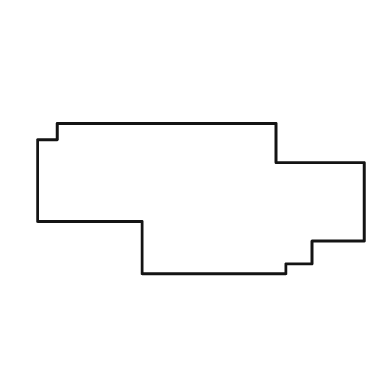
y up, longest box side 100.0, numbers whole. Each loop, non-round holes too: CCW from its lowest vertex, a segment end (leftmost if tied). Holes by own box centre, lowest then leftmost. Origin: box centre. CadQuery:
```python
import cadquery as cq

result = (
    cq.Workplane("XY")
    .moveTo(-18.0, -23.0)
    .lineTo(26.0, -23.0)
    .lineTo(26.0, -20.0)
    .lineTo(34.0, -20.0)
    .lineTo(34.0, -13.0)
    .lineTo(50.0, -13.0)
    .lineTo(50.0, 11.0)
    .lineTo(23.0, 11.0)
    .lineTo(23.0, 23.0)
    .lineTo(-44.0, 23.0)
    .lineTo(-44.0, 18.0)
    .lineTo(-50.0, 18.0)
    .lineTo(-50.0, -7.0)
    .lineTo(-18.0, -7.0)
    .close()
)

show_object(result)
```